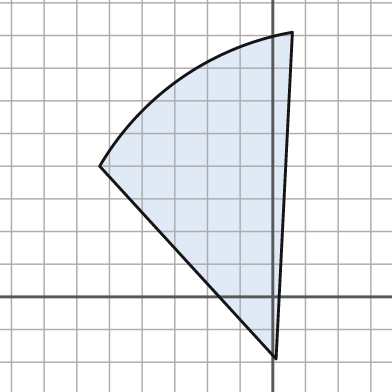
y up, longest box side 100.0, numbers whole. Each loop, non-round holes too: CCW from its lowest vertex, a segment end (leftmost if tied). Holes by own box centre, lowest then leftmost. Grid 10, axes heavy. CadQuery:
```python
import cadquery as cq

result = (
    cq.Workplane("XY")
    .moveTo(1.0, -19.0)
    .lineTo(6.0, 81.0)
    .threePointArc((-28.0, 67.0), (-53.0, 40.0))
    .close()
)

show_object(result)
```